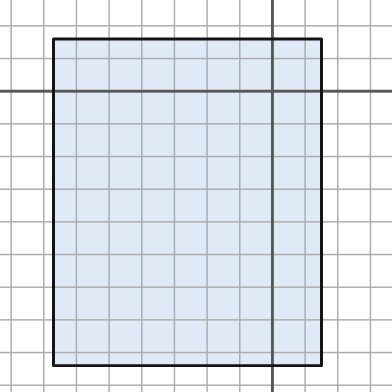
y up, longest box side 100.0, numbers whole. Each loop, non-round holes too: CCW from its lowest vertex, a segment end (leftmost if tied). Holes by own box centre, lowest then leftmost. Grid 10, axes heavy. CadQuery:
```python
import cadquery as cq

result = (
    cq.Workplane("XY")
    .moveTo(-67.0, -84.0)
    .lineTo(15.0, -84.0)
    .lineTo(15.0, 16.0)
    .lineTo(-67.0, 16.0)
    .close()
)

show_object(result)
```